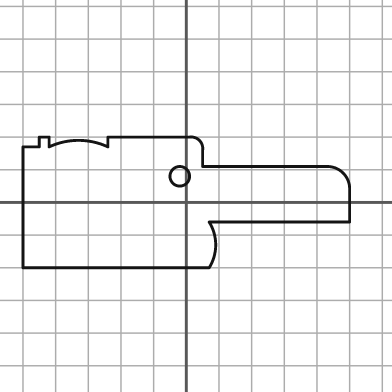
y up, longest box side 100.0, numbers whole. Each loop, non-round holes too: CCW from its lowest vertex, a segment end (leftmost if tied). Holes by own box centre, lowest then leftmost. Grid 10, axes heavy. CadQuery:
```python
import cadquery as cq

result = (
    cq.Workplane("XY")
    .moveTo(-50.0, -20.0)
    .lineTo(7.0, -20.0)
    .threePointArc((9.0, -13.0), (7.0, -6.0))
    .lineTo(50.0, -6.0)
    .lineTo(50.0, 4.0)
    .threePointArc((48.0, 9.0), (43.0, 11.0))
    .lineTo(5.0, 11.0)
    .lineTo(5.0, 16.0)
    .threePointArc((4.0, 19.0), (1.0, 20.0))
    .lineTo(-24.0, 20.0)
    .lineTo(-24.0, 17.0)
    .threePointArc((-33.0, 19.0), (-42.0, 17.0))
    .lineTo(-42.0, 20.0)
    .lineTo(-45.0, 20.0)
    .lineTo(-45.0, 17.0)
    .lineTo(-50.0, 17.0)
    .close()
    .moveTo(-2.0, 8.0)
    .circle(3.0)
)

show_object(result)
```